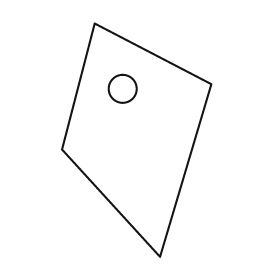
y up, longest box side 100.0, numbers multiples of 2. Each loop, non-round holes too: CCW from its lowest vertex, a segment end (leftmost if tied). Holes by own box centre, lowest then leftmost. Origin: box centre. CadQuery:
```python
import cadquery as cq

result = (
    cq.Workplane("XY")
    .moveTo(10.0, -50.0)
    .lineTo(32.0, 24.0)
    .lineTo(-18.0, 50.0)
    .lineTo(-32.0, -4.0)
    .close()
    .moveTo(-6.0, 22.0)
    .circle(6.0)
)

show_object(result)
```